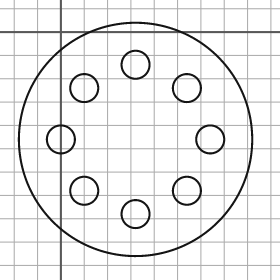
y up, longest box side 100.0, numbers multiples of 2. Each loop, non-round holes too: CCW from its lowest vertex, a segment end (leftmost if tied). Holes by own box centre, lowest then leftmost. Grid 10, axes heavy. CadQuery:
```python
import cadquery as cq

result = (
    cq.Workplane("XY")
    .moveTo(32.0, -46.0)
    .circle(50.0)
    .moveTo(32.0, -78.0)
    .circle(6.0)
    .moveTo(10.0, -68.0)
    .circle(6.0)
    .moveTo(54.0, -68.0)
    .circle(6.0)
    .moveTo(0.0, -46.0)
    .circle(6.0)
    .moveTo(64.0, -46.0)
    .circle(6.0)
    .moveTo(10.0, -24.0)
    .circle(6.0)
    .moveTo(54.0, -24.0)
    .circle(6.0)
    .moveTo(32.0, -14.0)
    .circle(6.0)
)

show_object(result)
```